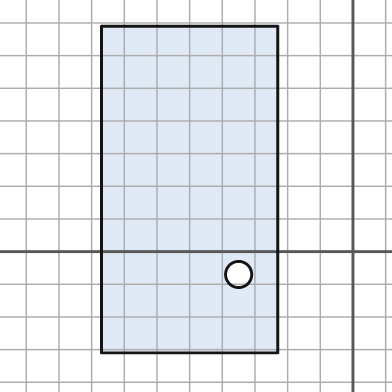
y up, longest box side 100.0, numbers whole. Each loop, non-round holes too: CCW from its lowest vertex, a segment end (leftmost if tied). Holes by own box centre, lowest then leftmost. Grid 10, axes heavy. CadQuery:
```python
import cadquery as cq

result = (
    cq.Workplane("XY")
    .moveTo(-77.0, -31.0)
    .lineTo(-23.0, -31.0)
    .lineTo(-23.0, 69.0)
    .lineTo(-77.0, 69.0)
    .close()
    .moveTo(-35.0, -7.0)
    .circle(4.0)
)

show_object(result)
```